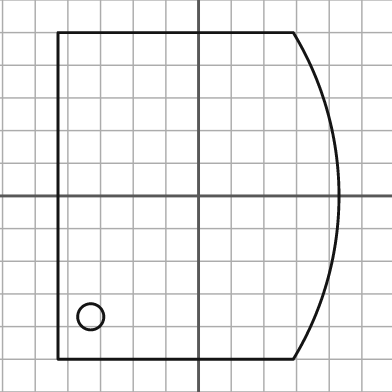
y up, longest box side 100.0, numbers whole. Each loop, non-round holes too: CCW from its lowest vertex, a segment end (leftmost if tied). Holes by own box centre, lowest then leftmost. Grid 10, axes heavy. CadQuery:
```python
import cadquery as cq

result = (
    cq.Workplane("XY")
    .moveTo(-43.0, -50.0)
    .lineTo(29.0, -50.0)
    .threePointArc((43.0, 0.0), (29.0, 50.0))
    .lineTo(-43.0, 50.0)
    .close()
    .moveTo(-33.0, -37.0)
    .circle(4.0)
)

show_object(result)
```